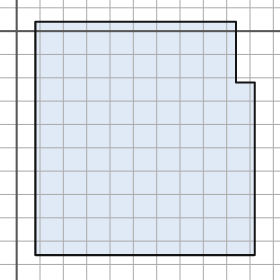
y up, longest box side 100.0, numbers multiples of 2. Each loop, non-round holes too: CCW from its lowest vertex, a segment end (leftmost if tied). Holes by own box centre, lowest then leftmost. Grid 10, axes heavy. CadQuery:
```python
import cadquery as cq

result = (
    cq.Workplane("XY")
    .moveTo(8.0, -96.0)
    .lineTo(102.0, -96.0)
    .lineTo(102.0, -22.0)
    .lineTo(94.0, -22.0)
    .lineTo(94.0, 4.0)
    .lineTo(8.0, 4.0)
    .close()
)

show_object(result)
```